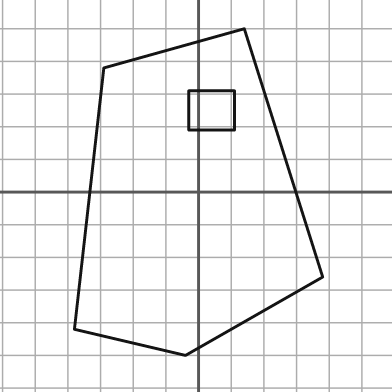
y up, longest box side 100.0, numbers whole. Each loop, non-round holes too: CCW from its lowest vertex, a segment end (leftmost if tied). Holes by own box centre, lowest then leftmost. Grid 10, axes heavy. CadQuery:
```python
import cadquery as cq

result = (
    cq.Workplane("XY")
    .moveTo(-4.0, -50.0)
    .lineTo(38.0, -26.0)
    .lineTo(14.0, 50.0)
    .lineTo(-29.0, 38.0)
    .lineTo(-38.0, -42.0)
    .close()
    .moveTo(-3.0, 19.0)
    .lineTo(11.0, 19.0)
    .lineTo(11.0, 31.0)
    .lineTo(-3.0, 31.0)
    .close()
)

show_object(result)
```